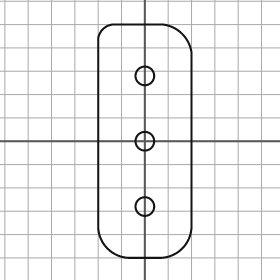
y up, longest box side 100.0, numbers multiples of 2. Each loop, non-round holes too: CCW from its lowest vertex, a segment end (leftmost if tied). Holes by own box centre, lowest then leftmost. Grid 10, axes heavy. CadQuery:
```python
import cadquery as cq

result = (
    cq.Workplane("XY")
    .moveTo(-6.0, -50.0)
    .lineTo(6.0, -50.0)
    .threePointArc((16.0, -46.0), (20.0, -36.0))
    .lineTo(20.0, 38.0)
    .threePointArc((16.0, 46.0), (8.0, 50.0))
    .lineTo(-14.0, 50.0)
    .threePointArc((-18.0, 48.0), (-20.0, 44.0))
    .lineTo(-20.0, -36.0)
    .threePointArc((-16.0, -46.0), (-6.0, -50.0))
    .close()
    .moveTo(0.0, -28.0)
    .circle(4.0)
    .moveTo(0.0, 0.0)
    .circle(4.0)
    .moveTo(0.0, 28.0)
    .circle(4.0)
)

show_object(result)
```